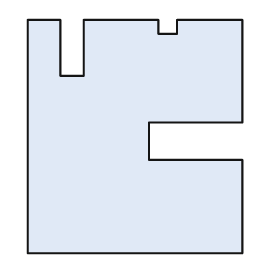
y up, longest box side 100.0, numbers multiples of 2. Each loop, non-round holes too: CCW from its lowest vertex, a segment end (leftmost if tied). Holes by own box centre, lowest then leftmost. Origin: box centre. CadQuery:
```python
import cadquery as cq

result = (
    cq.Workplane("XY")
    .moveTo(-46.0, -50.0)
    .lineTo(46.0, -50.0)
    .lineTo(46.0, -10.0)
    .lineTo(6.0, -10.0)
    .lineTo(6.0, 6.0)
    .lineTo(46.0, 6.0)
    .lineTo(46.0, 50.0)
    .lineTo(18.0, 50.0)
    .lineTo(18.0, 44.0)
    .lineTo(10.0, 44.0)
    .lineTo(10.0, 50.0)
    .lineTo(-22.0, 50.0)
    .lineTo(-22.0, 26.0)
    .lineTo(-32.0, 26.0)
    .lineTo(-32.0, 50.0)
    .lineTo(-46.0, 50.0)
    .close()
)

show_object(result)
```